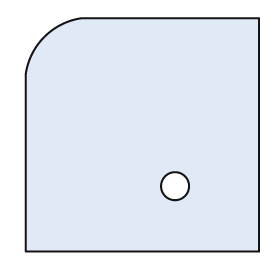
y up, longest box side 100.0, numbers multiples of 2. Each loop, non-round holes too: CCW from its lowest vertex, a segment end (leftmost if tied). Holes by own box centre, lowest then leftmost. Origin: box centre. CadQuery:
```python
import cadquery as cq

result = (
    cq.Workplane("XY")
    .moveTo(-50.0, -50.0)
    .lineTo(50.0, -50.0)
    .lineTo(50.0, 50.0)
    .lineTo(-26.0, 50.0)
    .threePointArc((-42.0, 42.0), (-50.0, 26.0))
    .close()
    .moveTo(14.0, -22.0)
    .circle(6.0)
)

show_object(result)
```